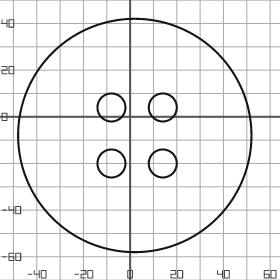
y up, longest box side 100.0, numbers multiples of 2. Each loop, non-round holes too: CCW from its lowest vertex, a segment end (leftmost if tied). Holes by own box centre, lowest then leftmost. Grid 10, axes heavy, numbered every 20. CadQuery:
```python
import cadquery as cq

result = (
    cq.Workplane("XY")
    .moveTo(2.0, -8.0)
    .circle(50.0)
    .moveTo(-8.0, -20.0)
    .circle(6.0)
    .moveTo(14.0, -20.0)
    .circle(6.0)
    .moveTo(-8.0, 4.0)
    .circle(6.0)
    .moveTo(14.0, 4.0)
    .circle(6.0)
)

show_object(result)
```